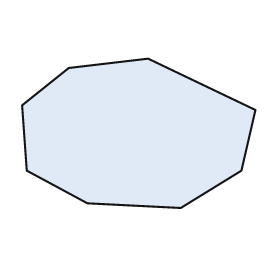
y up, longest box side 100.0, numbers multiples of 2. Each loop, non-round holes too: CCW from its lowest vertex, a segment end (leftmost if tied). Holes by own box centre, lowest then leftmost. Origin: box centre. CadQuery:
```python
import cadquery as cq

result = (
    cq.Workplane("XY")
    .moveTo(18.0, -32.0)
    .lineTo(44.0, -16.0)
    .lineTo(50.0, 10.0)
    .lineTo(4.0, 32.0)
    .lineTo(-30.0, 28.0)
    .lineTo(-50.0, 12.0)
    .lineTo(-48.0, -16.0)
    .lineTo(-22.0, -30.0)
    .close()
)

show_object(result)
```